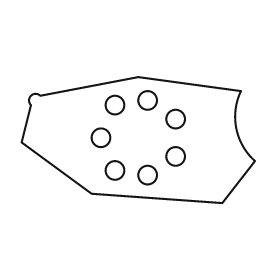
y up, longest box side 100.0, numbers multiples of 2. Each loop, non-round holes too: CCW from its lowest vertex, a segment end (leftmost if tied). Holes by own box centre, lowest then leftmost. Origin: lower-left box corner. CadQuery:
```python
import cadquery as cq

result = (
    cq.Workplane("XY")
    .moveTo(86.0, 0.0)
    .lineTo(100.0, 18.0)
    .threePointArc((92.0, 32.0), (94.0, 48.0))
    .lineTo(50.0, 54.0)
    .lineTo(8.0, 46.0)
    .threePointArc((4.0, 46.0), (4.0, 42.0))
    .lineTo(0.0, 26.0)
    .lineTo(30.0, 4.0)
    .close()
    .moveTo(54.0, 12.0)
    .circle(4.0)
    .moveTo(40.0, 14.0)
    .circle(4.0)
    .moveTo(66.0, 20.0)
    .circle(4.0)
    .moveTo(34.0, 28.0)
    .circle(4.0)
    .moveTo(66.0, 36.0)
    .circle(4.0)
    .moveTo(40.0, 42.0)
    .circle(4.0)
    .moveTo(54.0, 44.0)
    .circle(4.0)
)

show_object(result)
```